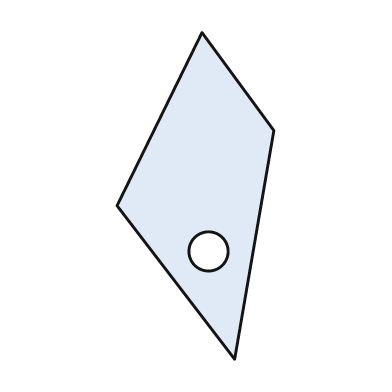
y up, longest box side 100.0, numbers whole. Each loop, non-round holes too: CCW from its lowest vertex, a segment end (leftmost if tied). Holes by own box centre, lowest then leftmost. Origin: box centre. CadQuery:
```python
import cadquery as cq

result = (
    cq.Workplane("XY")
    .moveTo(12.0, -50.0)
    .lineTo(24.0, 20.0)
    .lineTo(2.0, 50.0)
    .lineTo(-24.0, -3.0)
    .close()
    .moveTo(4.0, -17.0)
    .circle(6.0)
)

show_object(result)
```